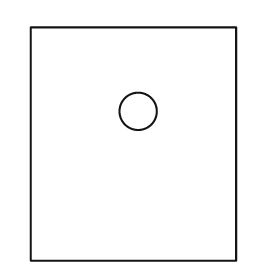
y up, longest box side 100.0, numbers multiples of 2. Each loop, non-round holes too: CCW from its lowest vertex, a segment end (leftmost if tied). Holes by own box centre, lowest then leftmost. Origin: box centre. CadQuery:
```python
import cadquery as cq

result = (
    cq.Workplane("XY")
    .moveTo(-44.0, -50.0)
    .lineTo(44.0, -50.0)
    .lineTo(44.0, 50.0)
    .lineTo(-44.0, 50.0)
    .close()
    .moveTo(2.0, 14.0)
    .circle(8.0)
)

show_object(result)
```